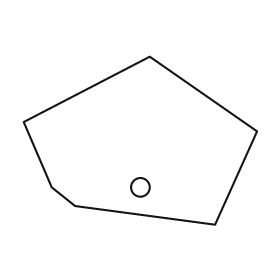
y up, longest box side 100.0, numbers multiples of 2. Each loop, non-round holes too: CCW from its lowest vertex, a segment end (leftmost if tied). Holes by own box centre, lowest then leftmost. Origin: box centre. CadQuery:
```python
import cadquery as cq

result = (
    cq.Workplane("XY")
    .moveTo(32.0, -36.0)
    .lineTo(50.0, 4.0)
    .lineTo(4.0, 36.0)
    .lineTo(-50.0, 8.0)
    .lineTo(-38.0, -20.0)
    .lineTo(-28.0, -28.0)
    .close()
    .moveTo(0.0, -20.0)
    .circle(4.0)
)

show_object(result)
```